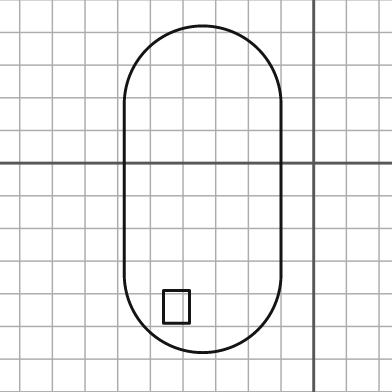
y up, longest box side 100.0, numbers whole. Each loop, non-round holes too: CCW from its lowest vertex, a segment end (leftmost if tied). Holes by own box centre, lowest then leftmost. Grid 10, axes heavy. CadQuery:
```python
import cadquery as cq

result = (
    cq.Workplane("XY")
    .moveTo(-58.0, -34.0)
    .threePointArc((-34.0, -58.0), (-10.0, -34.0))
    .lineTo(-10.0, 18.0)
    .threePointArc((-34.0, 42.0), (-58.0, 18.0))
    .close()
    .moveTo(-46.0, -49.0)
    .lineTo(-38.0, -49.0)
    .lineTo(-38.0, -39.0)
    .lineTo(-46.0, -39.0)
    .close()
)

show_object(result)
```